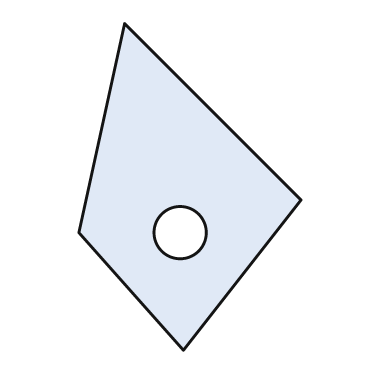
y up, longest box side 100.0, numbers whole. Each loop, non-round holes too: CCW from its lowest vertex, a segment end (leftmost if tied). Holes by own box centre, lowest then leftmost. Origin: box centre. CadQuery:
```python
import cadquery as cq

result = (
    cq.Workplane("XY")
    .moveTo(-2.0, -50.0)
    .lineTo(34.0, -4.0)
    .lineTo(-20.0, 50.0)
    .lineTo(-34.0, -14.0)
    .close()
    .moveTo(-3.0, -14.0)
    .circle(8.0)
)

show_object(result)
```